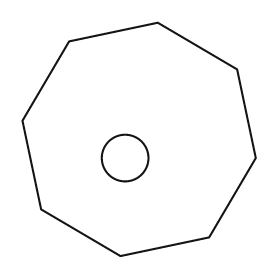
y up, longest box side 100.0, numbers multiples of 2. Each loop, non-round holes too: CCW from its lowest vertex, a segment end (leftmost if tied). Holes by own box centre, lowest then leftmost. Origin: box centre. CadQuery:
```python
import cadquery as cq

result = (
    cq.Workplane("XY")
    .moveTo(-8.0, -50.0)
    .lineTo(30.0, -42.0)
    .lineTo(50.0, -8.0)
    .lineTo(42.0, 30.0)
    .lineTo(8.0, 50.0)
    .lineTo(-30.0, 42.0)
    .lineTo(-50.0, 8.0)
    .lineTo(-42.0, -30.0)
    .close()
    .moveTo(-6.0, -8.0)
    .circle(10.0)
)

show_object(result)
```